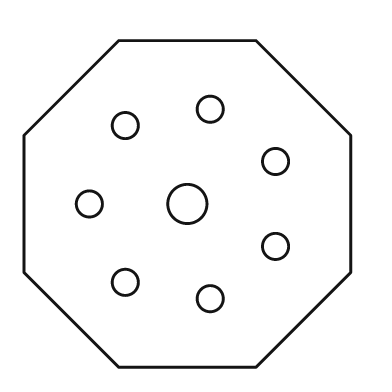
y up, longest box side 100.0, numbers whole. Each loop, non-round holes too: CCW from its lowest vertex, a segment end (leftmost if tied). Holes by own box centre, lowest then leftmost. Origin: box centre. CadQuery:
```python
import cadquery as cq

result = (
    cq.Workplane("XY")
    .moveTo(-21.0, -50.0)
    .lineTo(21.0, -50.0)
    .lineTo(50.0, -21.0)
    .lineTo(50.0, 21.0)
    .lineTo(21.0, 50.0)
    .lineTo(-21.0, 50.0)
    .lineTo(-50.0, 21.0)
    .lineTo(-50.0, -21.0)
    .close()
    .moveTo(7.0, -29.0)
    .circle(4.0)
    .moveTo(-19.0, -24.0)
    .circle(4.0)
    .moveTo(27.0, -13.0)
    .circle(4.0)
    .moveTo(-30.0, 0.0)
    .circle(4.0)
    .moveTo(0.0, 0.0)
    .circle(6.0)
    .moveTo(27.0, 13.0)
    .circle(4.0)
    .moveTo(-19.0, 24.0)
    .circle(4.0)
    .moveTo(7.0, 29.0)
    .circle(4.0)
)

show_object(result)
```